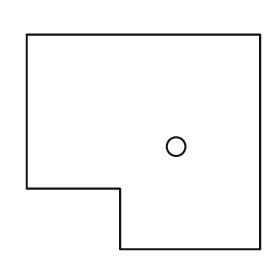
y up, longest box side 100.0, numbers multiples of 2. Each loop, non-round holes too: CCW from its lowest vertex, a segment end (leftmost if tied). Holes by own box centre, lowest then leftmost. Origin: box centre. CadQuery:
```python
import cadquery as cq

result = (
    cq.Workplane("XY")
    .moveTo(-10.0, -46.0)
    .lineTo(50.0, -46.0)
    .lineTo(50.0, 46.0)
    .lineTo(-50.0, 46.0)
    .lineTo(-50.0, -20.0)
    .lineTo(-10.0, -20.0)
    .close()
    .moveTo(14.0, -2.0)
    .circle(4.0)
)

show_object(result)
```